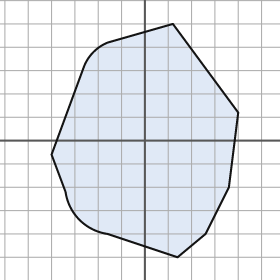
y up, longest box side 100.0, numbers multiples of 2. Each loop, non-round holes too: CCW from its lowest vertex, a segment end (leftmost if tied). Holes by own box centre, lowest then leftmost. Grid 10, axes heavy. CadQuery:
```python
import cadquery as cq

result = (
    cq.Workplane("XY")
    .moveTo(14.0, -50.0)
    .lineTo(26.0, -40.0)
    .lineTo(36.0, -20.0)
    .lineTo(40.0, 12.0)
    .lineTo(12.0, 50.0)
    .lineTo(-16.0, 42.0)
    .threePointArc((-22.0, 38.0), (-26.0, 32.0))
    .lineTo(-40.0, -6.0)
    .lineTo(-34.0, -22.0)
    .threePointArc((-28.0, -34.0), (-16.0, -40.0))
    .close()
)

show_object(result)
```